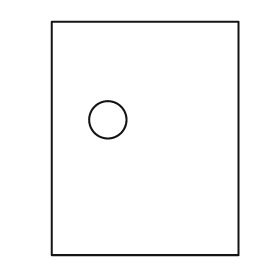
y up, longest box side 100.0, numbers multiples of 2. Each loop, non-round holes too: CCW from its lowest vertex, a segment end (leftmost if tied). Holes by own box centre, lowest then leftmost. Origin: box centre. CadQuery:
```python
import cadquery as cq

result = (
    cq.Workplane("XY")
    .moveTo(-40.0, -50.0)
    .lineTo(40.0, -50.0)
    .lineTo(40.0, 50.0)
    .lineTo(-40.0, 50.0)
    .close()
    .moveTo(-16.0, 8.0)
    .circle(8.0)
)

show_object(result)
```